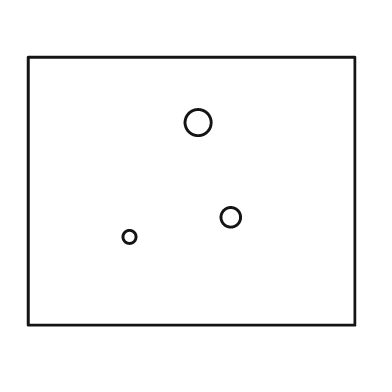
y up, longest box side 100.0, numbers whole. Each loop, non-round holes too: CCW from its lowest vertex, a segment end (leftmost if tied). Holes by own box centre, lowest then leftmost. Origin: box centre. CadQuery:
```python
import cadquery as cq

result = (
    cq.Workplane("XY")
    .moveTo(-50.0, -41.0)
    .lineTo(50.0, -41.0)
    .lineTo(50.0, 41.0)
    .lineTo(-50.0, 41.0)
    .close()
    .moveTo(-19.0, -14.0)
    .circle(2.0)
    .moveTo(12.0, -8.0)
    .circle(3.0)
    .moveTo(2.0, 21.0)
    .circle(4.0)
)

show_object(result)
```